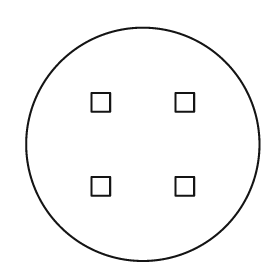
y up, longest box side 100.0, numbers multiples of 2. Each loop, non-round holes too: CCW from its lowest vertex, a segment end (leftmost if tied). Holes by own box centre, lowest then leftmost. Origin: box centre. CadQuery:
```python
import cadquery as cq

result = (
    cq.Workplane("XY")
    .moveTo(0.0, 0.0)
    .circle(50.0)
    .moveTo(-22.0, -22.0)
    .lineTo(-14.0, -22.0)
    .lineTo(-14.0, -14.0)
    .lineTo(-22.0, -14.0)
    .close()
    .moveTo(14.0, -22.0)
    .lineTo(22.0, -22.0)
    .lineTo(22.0, -14.0)
    .lineTo(14.0, -14.0)
    .close()
    .moveTo(-22.0, 14.0)
    .lineTo(-14.0, 14.0)
    .lineTo(-14.0, 22.0)
    .lineTo(-22.0, 22.0)
    .close()
    .moveTo(14.0, 14.0)
    .lineTo(22.0, 14.0)
    .lineTo(22.0, 22.0)
    .lineTo(14.0, 22.0)
    .close()
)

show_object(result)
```